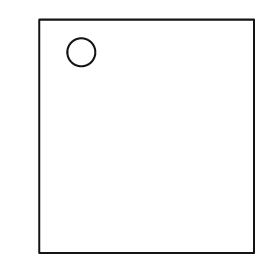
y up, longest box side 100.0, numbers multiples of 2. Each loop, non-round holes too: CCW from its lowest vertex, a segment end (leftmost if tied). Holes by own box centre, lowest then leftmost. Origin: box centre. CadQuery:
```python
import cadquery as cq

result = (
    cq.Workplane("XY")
    .moveTo(-46.0, -50.0)
    .lineTo(46.0, -50.0)
    .lineTo(46.0, 50.0)
    .lineTo(-46.0, 50.0)
    .close()
    .moveTo(-28.0, 36.0)
    .circle(6.0)
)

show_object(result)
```